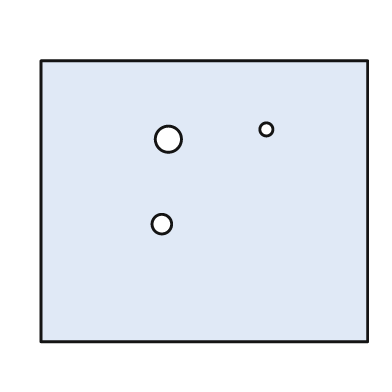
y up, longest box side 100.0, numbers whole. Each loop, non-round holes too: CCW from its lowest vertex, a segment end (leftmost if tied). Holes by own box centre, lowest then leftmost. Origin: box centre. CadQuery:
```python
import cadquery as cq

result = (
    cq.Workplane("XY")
    .moveTo(-50.0, -43.0)
    .lineTo(50.0, -43.0)
    .lineTo(50.0, 43.0)
    .lineTo(-50.0, 43.0)
    .close()
    .moveTo(-13.0, -7.0)
    .circle(3.0)
    .moveTo(-11.0, 19.0)
    .circle(4.0)
    .moveTo(19.0, 22.0)
    .circle(2.0)
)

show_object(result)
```